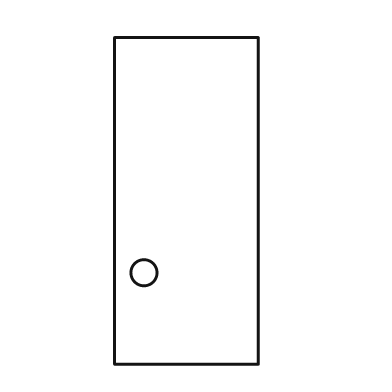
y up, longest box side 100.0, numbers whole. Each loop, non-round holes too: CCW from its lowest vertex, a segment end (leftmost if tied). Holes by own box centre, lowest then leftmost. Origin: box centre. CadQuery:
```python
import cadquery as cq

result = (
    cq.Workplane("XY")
    .moveTo(-22.0, -50.0)
    .lineTo(22.0, -50.0)
    .lineTo(22.0, 50.0)
    .lineTo(-22.0, 50.0)
    .close()
    .moveTo(-13.0, -22.0)
    .circle(4.0)
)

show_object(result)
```